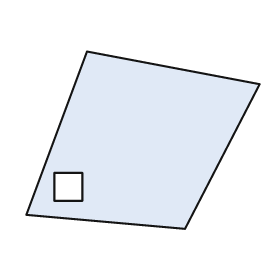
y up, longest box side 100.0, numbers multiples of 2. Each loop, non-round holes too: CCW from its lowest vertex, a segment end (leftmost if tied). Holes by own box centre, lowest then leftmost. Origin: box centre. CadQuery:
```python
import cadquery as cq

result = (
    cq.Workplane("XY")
    .moveTo(18.0, -38.0)
    .lineTo(50.0, 24.0)
    .lineTo(-24.0, 38.0)
    .lineTo(-50.0, -32.0)
    .close()
    .moveTo(-38.0, -26.0)
    .lineTo(-26.0, -26.0)
    .lineTo(-26.0, -14.0)
    .lineTo(-38.0, -14.0)
    .close()
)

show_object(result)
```